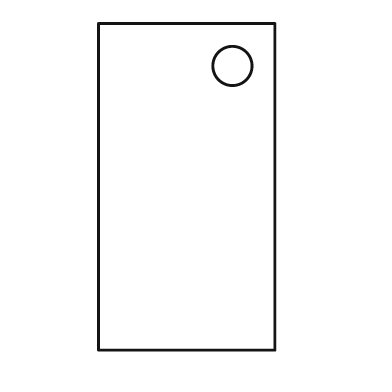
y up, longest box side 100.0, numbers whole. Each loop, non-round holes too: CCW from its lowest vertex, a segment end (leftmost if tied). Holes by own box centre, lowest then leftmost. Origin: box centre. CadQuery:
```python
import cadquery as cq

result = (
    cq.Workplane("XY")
    .moveTo(-27.0, -50.0)
    .lineTo(27.0, -50.0)
    .lineTo(27.0, 50.0)
    .lineTo(-27.0, 50.0)
    .close()
    .moveTo(14.0, 37.0)
    .circle(6.0)
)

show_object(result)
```